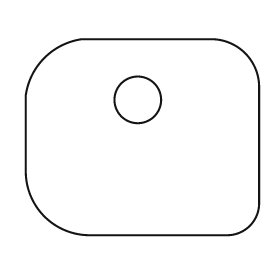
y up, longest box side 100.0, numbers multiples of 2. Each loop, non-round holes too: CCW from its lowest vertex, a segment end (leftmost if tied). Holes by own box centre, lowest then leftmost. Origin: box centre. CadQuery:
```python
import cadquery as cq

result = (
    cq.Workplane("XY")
    .moveTo(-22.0, -42.0)
    .lineTo(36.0, -42.0)
    .threePointArc((46.0, -38.0), (50.0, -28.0))
    .lineTo(50.0, 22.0)
    .threePointArc((44.0, 36.0), (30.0, 42.0))
    .lineTo(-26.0, 42.0)
    .threePointArc((-42.0, 34.0), (-50.0, 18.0))
    .lineTo(-50.0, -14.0)
    .threePointArc((-42.0, -34.0), (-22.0, -42.0))
    .close()
    .moveTo(-2.0, 16.0)
    .circle(10.0)
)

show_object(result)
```